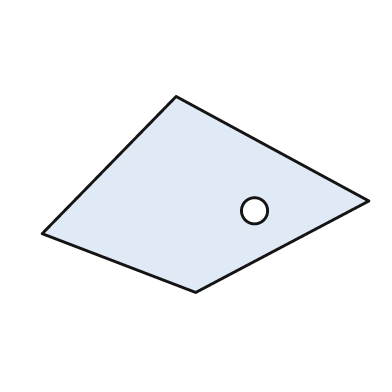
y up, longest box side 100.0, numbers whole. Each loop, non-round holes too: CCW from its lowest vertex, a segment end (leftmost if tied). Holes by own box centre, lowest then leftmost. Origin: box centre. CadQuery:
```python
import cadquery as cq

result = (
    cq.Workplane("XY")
    .moveTo(-3.0, -30.0)
    .lineTo(50.0, -2.0)
    .lineTo(-9.0, 30.0)
    .lineTo(-50.0, -12.0)
    .close()
    .moveTo(15.0, -5.0)
    .circle(4.0)
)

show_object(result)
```